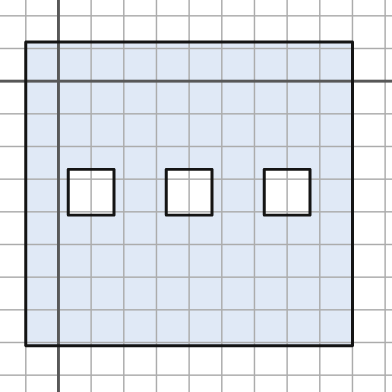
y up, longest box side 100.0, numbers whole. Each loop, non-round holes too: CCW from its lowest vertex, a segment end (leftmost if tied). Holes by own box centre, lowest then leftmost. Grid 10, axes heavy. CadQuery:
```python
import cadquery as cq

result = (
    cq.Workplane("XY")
    .moveTo(-10.0, -81.0)
    .lineTo(90.0, -81.0)
    .lineTo(90.0, 12.0)
    .lineTo(-10.0, 12.0)
    .close()
    .moveTo(3.0, -41.0)
    .lineTo(17.0, -41.0)
    .lineTo(17.0, -27.0)
    .lineTo(3.0, -27.0)
    .close()
    .moveTo(33.0, -41.0)
    .lineTo(47.0, -41.0)
    .lineTo(47.0, -27.0)
    .lineTo(33.0, -27.0)
    .close()
    .moveTo(63.0, -41.0)
    .lineTo(77.0, -41.0)
    .lineTo(77.0, -27.0)
    .lineTo(63.0, -27.0)
    .close()
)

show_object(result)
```